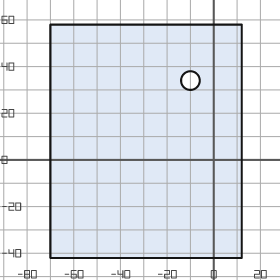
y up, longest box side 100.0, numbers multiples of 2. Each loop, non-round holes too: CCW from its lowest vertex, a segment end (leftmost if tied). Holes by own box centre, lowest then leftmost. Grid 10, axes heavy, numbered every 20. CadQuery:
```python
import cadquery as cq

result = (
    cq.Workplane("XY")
    .moveTo(-70.0, -42.0)
    .lineTo(12.0, -42.0)
    .lineTo(12.0, 58.0)
    .lineTo(-70.0, 58.0)
    .close()
    .moveTo(-10.0, 34.0)
    .circle(4.0)
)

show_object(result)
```